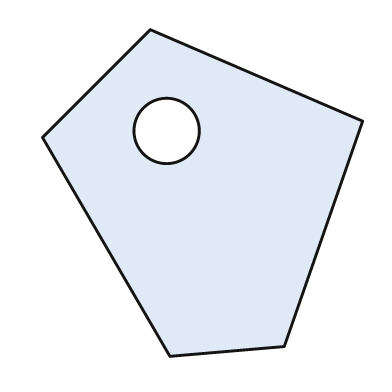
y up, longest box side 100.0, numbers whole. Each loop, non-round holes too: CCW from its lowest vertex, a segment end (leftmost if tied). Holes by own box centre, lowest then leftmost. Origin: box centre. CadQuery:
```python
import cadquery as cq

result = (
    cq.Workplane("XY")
    .moveTo(-10.0, -50.0)
    .lineTo(25.0, -47.0)
    .lineTo(49.0, 22.0)
    .lineTo(-16.0, 50.0)
    .lineTo(-49.0, 17.0)
    .close()
    .moveTo(-11.0, 19.0)
    .circle(10.0)
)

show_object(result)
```